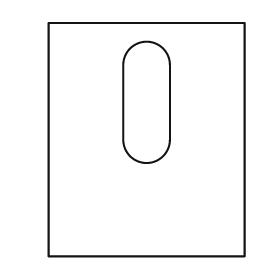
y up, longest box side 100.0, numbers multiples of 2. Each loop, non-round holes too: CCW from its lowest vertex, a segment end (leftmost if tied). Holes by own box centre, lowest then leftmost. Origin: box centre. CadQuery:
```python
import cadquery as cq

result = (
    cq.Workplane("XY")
    .moveTo(-42.0, -50.0)
    .lineTo(42.0, -50.0)
    .lineTo(42.0, 50.0)
    .lineTo(-42.0, 50.0)
    .close()
    .moveTo(-10.0, 0.0)
    .threePointArc((0.0, -10.0), (10.0, 0.0))
    .lineTo(10.0, 32.0)
    .threePointArc((0.0, 42.0), (-10.0, 32.0))
    .close()
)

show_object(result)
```